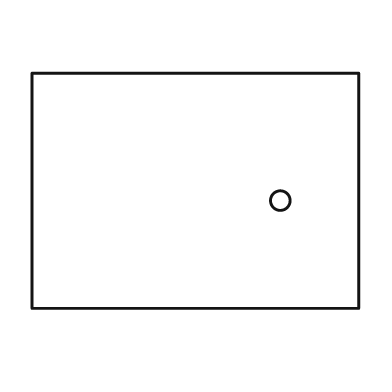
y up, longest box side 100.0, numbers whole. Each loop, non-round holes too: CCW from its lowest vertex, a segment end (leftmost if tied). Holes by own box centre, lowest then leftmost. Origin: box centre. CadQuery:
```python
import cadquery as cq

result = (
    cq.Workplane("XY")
    .moveTo(-50.0, -36.0)
    .lineTo(50.0, -36.0)
    .lineTo(50.0, 36.0)
    .lineTo(-50.0, 36.0)
    .close()
    .moveTo(26.0, -3.0)
    .circle(3.0)
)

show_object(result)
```